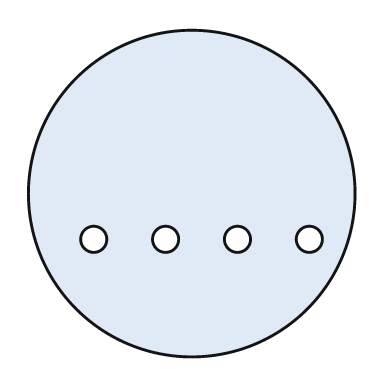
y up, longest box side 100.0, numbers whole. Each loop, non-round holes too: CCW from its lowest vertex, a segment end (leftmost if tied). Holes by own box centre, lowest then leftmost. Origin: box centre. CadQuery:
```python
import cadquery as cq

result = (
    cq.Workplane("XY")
    .moveTo(0.0, 0.0)
    .circle(50.0)
    .moveTo(-30.0, -14.0)
    .circle(4.0)
    .moveTo(-8.0, -14.0)
    .circle(4.0)
    .moveTo(14.0, -14.0)
    .circle(4.0)
    .moveTo(36.0, -14.0)
    .circle(4.0)
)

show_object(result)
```